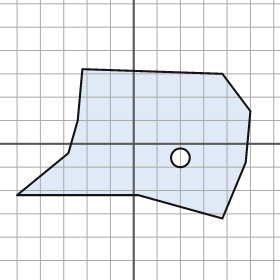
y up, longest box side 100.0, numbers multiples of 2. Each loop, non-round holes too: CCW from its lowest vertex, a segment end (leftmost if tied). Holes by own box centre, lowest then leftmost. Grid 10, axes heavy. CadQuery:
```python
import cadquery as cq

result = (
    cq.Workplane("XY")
    .moveTo(38.0, -32.0)
    .lineTo(48.0, -8.0)
    .lineTo(50.0, 14.0)
    .lineTo(38.0, 30.0)
    .lineTo(-22.0, 32.0)
    .lineTo(-24.0, 10.0)
    .lineTo(-28.0, -4.0)
    .lineTo(-50.0, -22.0)
    .lineTo(2.0, -22.0)
    .close()
    .moveTo(20.0, -6.0)
    .circle(4.0)
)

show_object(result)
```